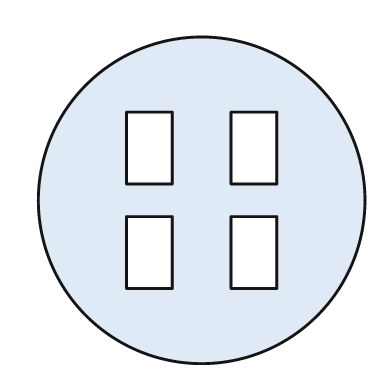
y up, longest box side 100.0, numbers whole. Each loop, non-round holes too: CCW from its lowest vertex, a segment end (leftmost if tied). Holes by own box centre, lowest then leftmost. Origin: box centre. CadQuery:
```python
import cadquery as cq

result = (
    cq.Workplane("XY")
    .moveTo(0.0, 0.0)
    .circle(50.0)
    .moveTo(-23.0, -27.0)
    .lineTo(-9.0, -27.0)
    .lineTo(-9.0, -5.0)
    .lineTo(-23.0, -5.0)
    .close()
    .moveTo(9.0, -27.0)
    .lineTo(23.0, -27.0)
    .lineTo(23.0, -5.0)
    .lineTo(9.0, -5.0)
    .close()
    .moveTo(-23.0, 5.0)
    .lineTo(-9.0, 5.0)
    .lineTo(-9.0, 27.0)
    .lineTo(-23.0, 27.0)
    .close()
    .moveTo(9.0, 5.0)
    .lineTo(23.0, 5.0)
    .lineTo(23.0, 27.0)
    .lineTo(9.0, 27.0)
    .close()
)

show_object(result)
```